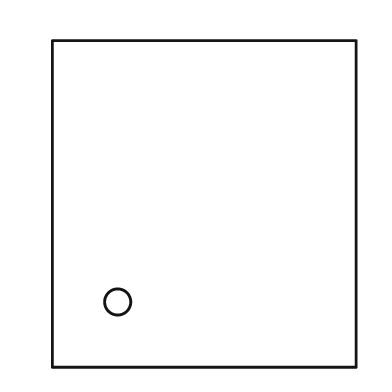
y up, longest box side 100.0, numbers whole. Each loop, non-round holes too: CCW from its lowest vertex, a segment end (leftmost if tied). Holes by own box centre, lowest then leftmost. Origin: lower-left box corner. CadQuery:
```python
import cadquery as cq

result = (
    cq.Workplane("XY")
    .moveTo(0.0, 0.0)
    .lineTo(93.0, 0.0)
    .lineTo(93.0, 100.0)
    .lineTo(0.0, 100.0)
    .close()
    .moveTo(20.0, 20.0)
    .circle(4.0)
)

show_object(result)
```